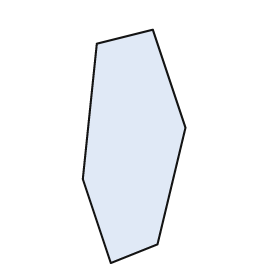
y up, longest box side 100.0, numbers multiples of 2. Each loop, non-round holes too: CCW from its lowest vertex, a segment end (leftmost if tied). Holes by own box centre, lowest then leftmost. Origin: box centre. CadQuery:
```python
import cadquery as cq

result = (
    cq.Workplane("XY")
    .moveTo(-10.0, -50.0)
    .lineTo(10.0, -42.0)
    .lineTo(22.0, 8.0)
    .lineTo(8.0, 50.0)
    .lineTo(-16.0, 44.0)
    .lineTo(-22.0, -14.0)
    .close()
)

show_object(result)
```